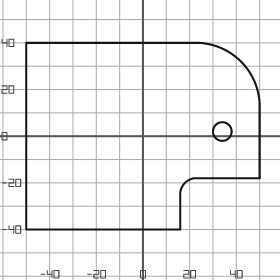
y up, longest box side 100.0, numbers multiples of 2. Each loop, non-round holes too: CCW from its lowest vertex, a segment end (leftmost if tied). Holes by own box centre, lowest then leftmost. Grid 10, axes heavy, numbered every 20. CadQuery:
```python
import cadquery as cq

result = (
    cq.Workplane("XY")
    .moveTo(-50.0, -40.0)
    .lineTo(16.0, -40.0)
    .lineTo(16.0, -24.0)
    .threePointArc((18.0, -20.0), (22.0, -18.0))
    .lineTo(50.0, -18.0)
    .lineTo(50.0, 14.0)
    .threePointArc((42.0, 32.0), (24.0, 40.0))
    .lineTo(-50.0, 40.0)
    .close()
    .moveTo(34.0, 2.0)
    .circle(4.0)
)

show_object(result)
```